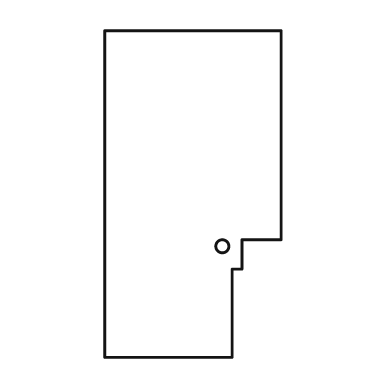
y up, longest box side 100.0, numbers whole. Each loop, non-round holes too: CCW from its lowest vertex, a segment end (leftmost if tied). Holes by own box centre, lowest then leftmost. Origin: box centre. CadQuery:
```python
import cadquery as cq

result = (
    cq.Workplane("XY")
    .moveTo(-27.0, -50.0)
    .lineTo(12.0, -50.0)
    .lineTo(12.0, -23.0)
    .lineTo(15.0, -23.0)
    .lineTo(15.0, -14.0)
    .lineTo(27.0, -14.0)
    .lineTo(27.0, 50.0)
    .lineTo(-27.0, 50.0)
    .close()
    .moveTo(9.0, -16.0)
    .circle(2.0)
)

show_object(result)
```